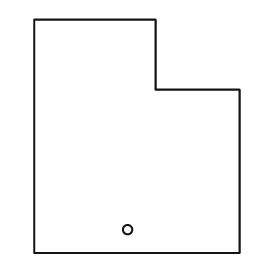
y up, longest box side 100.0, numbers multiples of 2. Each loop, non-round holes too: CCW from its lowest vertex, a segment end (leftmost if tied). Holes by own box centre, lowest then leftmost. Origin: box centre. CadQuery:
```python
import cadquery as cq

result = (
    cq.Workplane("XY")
    .moveTo(-44.0, -50.0)
    .lineTo(44.0, -50.0)
    .lineTo(44.0, 20.0)
    .lineTo(8.0, 20.0)
    .lineTo(8.0, 50.0)
    .lineTo(-44.0, 50.0)
    .close()
    .moveTo(-4.0, -40.0)
    .circle(2.0)
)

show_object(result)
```